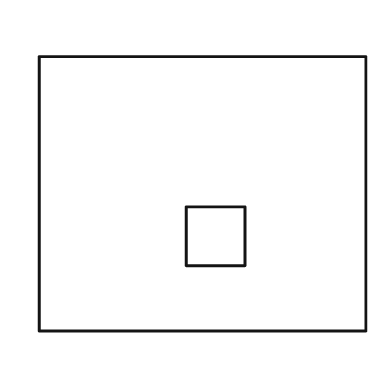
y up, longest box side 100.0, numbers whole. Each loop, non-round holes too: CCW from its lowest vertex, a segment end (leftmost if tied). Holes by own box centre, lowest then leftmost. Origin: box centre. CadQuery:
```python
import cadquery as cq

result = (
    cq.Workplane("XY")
    .moveTo(-50.0, -42.0)
    .lineTo(50.0, -42.0)
    .lineTo(50.0, 42.0)
    .lineTo(-50.0, 42.0)
    .close()
    .moveTo(-5.0, -22.0)
    .lineTo(13.0, -22.0)
    .lineTo(13.0, -4.0)
    .lineTo(-5.0, -4.0)
    .close()
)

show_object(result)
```